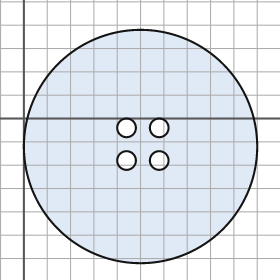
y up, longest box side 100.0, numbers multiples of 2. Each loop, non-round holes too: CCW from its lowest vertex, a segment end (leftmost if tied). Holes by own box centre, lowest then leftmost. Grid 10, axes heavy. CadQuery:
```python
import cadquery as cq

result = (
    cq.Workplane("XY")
    .moveTo(50.0, -12.0)
    .circle(50.0)
    .moveTo(44.0, -18.0)
    .circle(4.0)
    .moveTo(58.0, -18.0)
    .circle(4.0)
    .moveTo(44.0, -4.0)
    .circle(4.0)
    .moveTo(58.0, -4.0)
    .circle(4.0)
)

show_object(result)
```